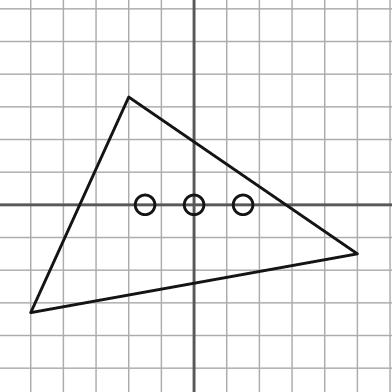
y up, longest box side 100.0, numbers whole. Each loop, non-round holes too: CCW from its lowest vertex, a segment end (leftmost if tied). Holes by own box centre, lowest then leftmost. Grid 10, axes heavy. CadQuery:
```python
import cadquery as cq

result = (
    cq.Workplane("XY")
    .moveTo(-50.0, -33.0)
    .lineTo(50.0, -15.0)
    .lineTo(-20.0, 33.0)
    .close()
    .moveTo(-15.0, 0.0)
    .circle(3.0)
    .moveTo(0.0, 0.0)
    .circle(3.0)
    .moveTo(15.0, 0.0)
    .circle(3.0)
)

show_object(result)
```